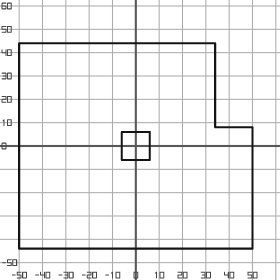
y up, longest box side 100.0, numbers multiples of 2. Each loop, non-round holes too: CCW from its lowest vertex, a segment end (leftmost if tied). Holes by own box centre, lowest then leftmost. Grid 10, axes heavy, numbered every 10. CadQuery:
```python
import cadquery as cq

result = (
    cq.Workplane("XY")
    .moveTo(-50.0, -44.0)
    .lineTo(50.0, -44.0)
    .lineTo(50.0, 8.0)
    .lineTo(34.0, 8.0)
    .lineTo(34.0, 44.0)
    .lineTo(-50.0, 44.0)
    .close()
    .moveTo(-6.0, -6.0)
    .lineTo(6.0, -6.0)
    .lineTo(6.0, 6.0)
    .lineTo(-6.0, 6.0)
    .close()
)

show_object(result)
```